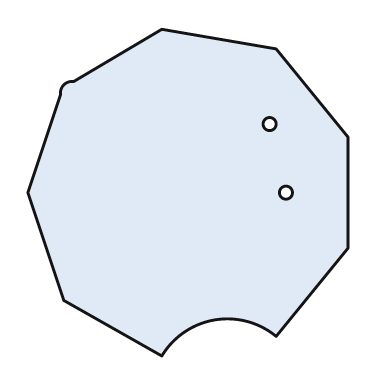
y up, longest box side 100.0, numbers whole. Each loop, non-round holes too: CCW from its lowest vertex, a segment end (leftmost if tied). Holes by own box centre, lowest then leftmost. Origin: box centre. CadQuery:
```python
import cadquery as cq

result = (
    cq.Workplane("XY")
    .moveTo(-8.0, -50.0)
    .threePointArc((8.0, -39.0), (27.0, -44.0))
    .lineTo(49.0, -17.0)
    .lineTo(49.0, 17.0)
    .lineTo(27.0, 44.0)
    .lineTo(-8.0, 50.0)
    .lineTo(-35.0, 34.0)
    .threePointArc((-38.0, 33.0), (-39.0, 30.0))
    .lineTo(-49.0, 0.0)
    .lineTo(-38.0, -33.0)
    .close()
    .moveTo(30.0, 0.0)
    .circle(2.0)
    .moveTo(25.0, 21.0)
    .circle(2.0)
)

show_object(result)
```